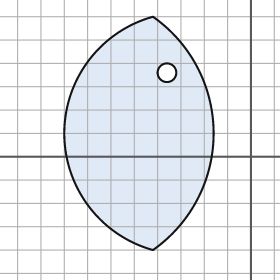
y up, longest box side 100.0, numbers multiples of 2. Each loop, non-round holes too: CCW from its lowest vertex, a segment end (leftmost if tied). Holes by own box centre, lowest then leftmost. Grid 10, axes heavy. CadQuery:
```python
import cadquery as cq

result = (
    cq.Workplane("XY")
    .moveTo(-42.0, -40.0)
    .threePointArc((-16.0, 10.0), (-42.0, 60.0))
    .threePointArc((-80.0, 10.0), (-42.0, -40.0))
    .close()
    .moveTo(-36.0, 36.0)
    .circle(4.0)
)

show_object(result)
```